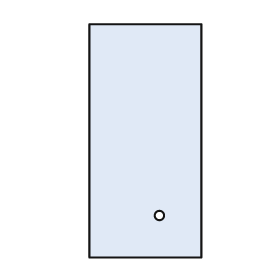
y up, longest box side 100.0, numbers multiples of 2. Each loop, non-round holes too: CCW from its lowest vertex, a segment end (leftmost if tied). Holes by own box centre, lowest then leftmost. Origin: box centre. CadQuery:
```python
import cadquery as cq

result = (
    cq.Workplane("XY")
    .moveTo(-24.0, -50.0)
    .lineTo(24.0, -50.0)
    .lineTo(24.0, 50.0)
    .lineTo(-24.0, 50.0)
    .close()
    .moveTo(6.0, -32.0)
    .circle(2.0)
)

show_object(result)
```